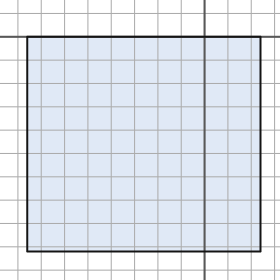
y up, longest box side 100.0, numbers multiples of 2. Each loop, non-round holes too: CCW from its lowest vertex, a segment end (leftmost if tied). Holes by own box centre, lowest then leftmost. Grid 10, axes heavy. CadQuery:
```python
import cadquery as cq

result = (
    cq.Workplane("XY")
    .moveTo(-76.0, -92.0)
    .lineTo(24.0, -92.0)
    .lineTo(24.0, 0.0)
    .lineTo(-76.0, 0.0)
    .close()
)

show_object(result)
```